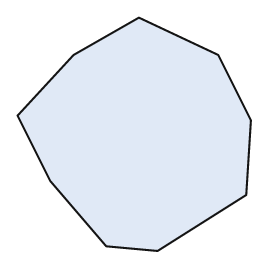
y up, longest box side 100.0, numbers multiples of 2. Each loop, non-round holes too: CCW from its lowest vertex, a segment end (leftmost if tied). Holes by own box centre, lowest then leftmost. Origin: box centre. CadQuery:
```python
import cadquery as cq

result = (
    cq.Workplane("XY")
    .moveTo(10.0, -50.0)
    .lineTo(48.0, -26.0)
    .lineTo(50.0, 6.0)
    .lineTo(36.0, 34.0)
    .lineTo(2.0, 50.0)
    .lineTo(-26.0, 34.0)
    .lineTo(-50.0, 8.0)
    .lineTo(-36.0, -20.0)
    .lineTo(-12.0, -48.0)
    .close()
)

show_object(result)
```